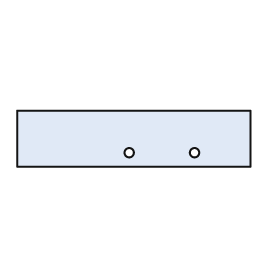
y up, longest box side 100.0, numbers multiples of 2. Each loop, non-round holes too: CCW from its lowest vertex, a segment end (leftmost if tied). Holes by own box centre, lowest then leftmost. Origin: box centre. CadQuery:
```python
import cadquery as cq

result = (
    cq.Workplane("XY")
    .moveTo(-50.0, -12.0)
    .lineTo(50.0, -12.0)
    .lineTo(50.0, 12.0)
    .lineTo(-50.0, 12.0)
    .close()
    .moveTo(-2.0, -6.0)
    .circle(2.0)
    .moveTo(26.0, -6.0)
    .circle(2.0)
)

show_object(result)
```